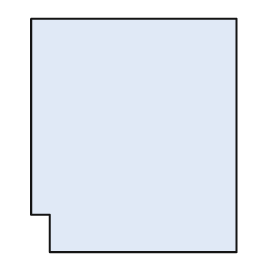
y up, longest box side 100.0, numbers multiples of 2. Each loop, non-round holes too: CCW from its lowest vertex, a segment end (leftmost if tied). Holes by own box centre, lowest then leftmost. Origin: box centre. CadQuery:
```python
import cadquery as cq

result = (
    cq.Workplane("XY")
    .moveTo(-36.0, -50.0)
    .lineTo(44.0, -50.0)
    .lineTo(44.0, 50.0)
    .lineTo(-44.0, 50.0)
    .lineTo(-44.0, -34.0)
    .lineTo(-36.0, -34.0)
    .close()
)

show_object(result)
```